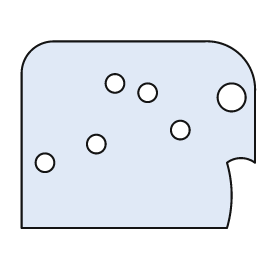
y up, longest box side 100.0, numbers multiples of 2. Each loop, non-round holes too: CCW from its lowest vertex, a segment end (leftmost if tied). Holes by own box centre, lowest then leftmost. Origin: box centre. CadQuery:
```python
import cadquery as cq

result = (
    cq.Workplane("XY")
    .moveTo(-50.0, -40.0)
    .lineTo(38.0, -40.0)
    .threePointArc((40.0, -26.0), (38.0, -12.0))
    .threePointArc((44.0, -10.0), (50.0, -12.0))
    .lineTo(50.0, 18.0)
    .threePointArc((44.0, 34.0), (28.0, 40.0))
    .lineTo(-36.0, 40.0)
    .threePointArc((-46.0, 36.0), (-50.0, 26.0))
    .close()
    .moveTo(-40.0, -12.0)
    .circle(4.0)
    .moveTo(-18.0, -4.0)
    .circle(4.0)
    .moveTo(18.0, 2.0)
    .circle(4.0)
    .moveTo(40.0, 16.0)
    .circle(6.0)
    .moveTo(4.0, 18.0)
    .circle(4.0)
    .moveTo(-10.0, 22.0)
    .circle(4.0)
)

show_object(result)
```